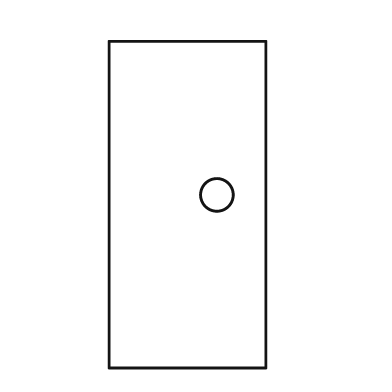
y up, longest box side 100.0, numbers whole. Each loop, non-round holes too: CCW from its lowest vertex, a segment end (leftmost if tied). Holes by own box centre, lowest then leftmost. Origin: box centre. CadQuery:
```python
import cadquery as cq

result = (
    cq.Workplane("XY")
    .moveTo(-24.0, -50.0)
    .lineTo(24.0, -50.0)
    .lineTo(24.0, 50.0)
    .lineTo(-24.0, 50.0)
    .close()
    .moveTo(9.0, 3.0)
    .circle(5.0)
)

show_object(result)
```